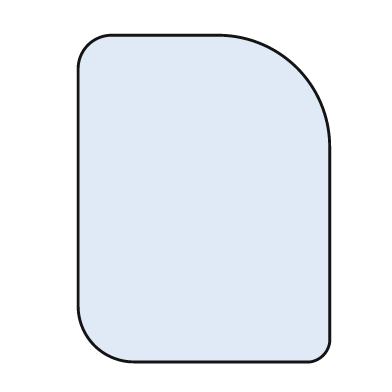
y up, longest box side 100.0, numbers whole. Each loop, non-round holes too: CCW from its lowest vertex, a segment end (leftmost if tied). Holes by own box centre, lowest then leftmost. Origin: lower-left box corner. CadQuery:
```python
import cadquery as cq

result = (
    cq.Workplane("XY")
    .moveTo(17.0, 0.0)
    .lineTo(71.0, 0.0)
    .threePointArc((75.0, 2.0), (77.0, 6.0))
    .lineTo(77.0, 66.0)
    .threePointArc((67.0, 90.0), (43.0, 100.0))
    .lineTo(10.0, 100.0)
    .threePointArc((3.0, 97.0), (0.0, 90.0))
    .lineTo(0.0, 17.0)
    .threePointArc((5.0, 5.0), (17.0, 0.0))
    .close()
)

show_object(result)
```